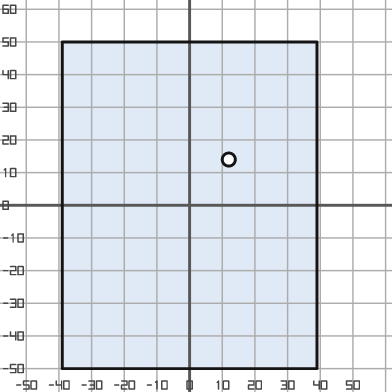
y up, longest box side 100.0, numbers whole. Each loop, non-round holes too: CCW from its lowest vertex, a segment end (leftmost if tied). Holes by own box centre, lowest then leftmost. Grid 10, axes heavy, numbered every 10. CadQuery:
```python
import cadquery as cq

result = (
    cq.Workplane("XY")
    .moveTo(-39.0, -50.0)
    .lineTo(39.0, -50.0)
    .lineTo(39.0, 50.0)
    .lineTo(-39.0, 50.0)
    .close()
    .moveTo(12.0, 14.0)
    .circle(2.0)
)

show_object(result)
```